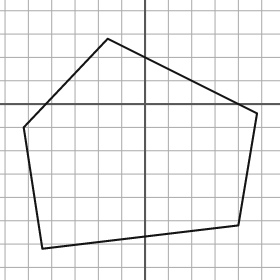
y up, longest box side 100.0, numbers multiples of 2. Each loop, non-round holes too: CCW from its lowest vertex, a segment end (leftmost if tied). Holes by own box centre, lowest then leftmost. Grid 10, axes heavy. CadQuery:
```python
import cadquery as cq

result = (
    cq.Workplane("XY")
    .moveTo(-44.0, -62.0)
    .lineTo(40.0, -52.0)
    .lineTo(48.0, -4.0)
    .lineTo(-16.0, 28.0)
    .lineTo(-52.0, -10.0)
    .close()
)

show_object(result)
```